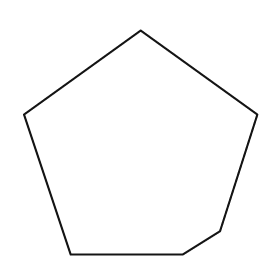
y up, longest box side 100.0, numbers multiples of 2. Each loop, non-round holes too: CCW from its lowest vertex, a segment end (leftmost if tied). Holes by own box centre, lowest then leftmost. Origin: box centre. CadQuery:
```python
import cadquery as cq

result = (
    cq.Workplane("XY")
    .moveTo(-30.0, -48.0)
    .lineTo(18.0, -48.0)
    .lineTo(34.0, -38.0)
    .lineTo(50.0, 12.0)
    .lineTo(0.0, 48.0)
    .lineTo(-50.0, 12.0)
    .close()
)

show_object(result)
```